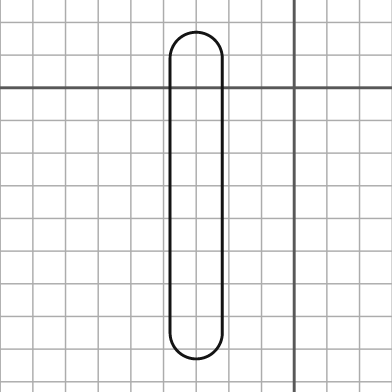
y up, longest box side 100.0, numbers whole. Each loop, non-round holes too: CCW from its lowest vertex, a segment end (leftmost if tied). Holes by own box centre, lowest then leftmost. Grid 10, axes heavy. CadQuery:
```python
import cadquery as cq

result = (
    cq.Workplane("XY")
    .moveTo(-38.0, -75.0)
    .threePointArc((-30.0, -83.0), (-22.0, -75.0))
    .lineTo(-22.0, 9.0)
    .threePointArc((-30.0, 17.0), (-38.0, 9.0))
    .close()
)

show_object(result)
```